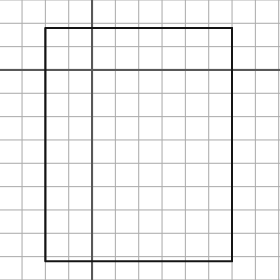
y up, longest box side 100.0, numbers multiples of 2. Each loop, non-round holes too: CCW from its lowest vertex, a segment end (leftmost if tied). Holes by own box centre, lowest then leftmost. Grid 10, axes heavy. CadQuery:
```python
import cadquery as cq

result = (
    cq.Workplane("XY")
    .moveTo(-20.0, -82.0)
    .lineTo(60.0, -82.0)
    .lineTo(60.0, 18.0)
    .lineTo(-20.0, 18.0)
    .close()
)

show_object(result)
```